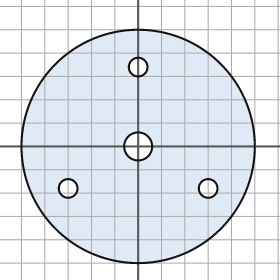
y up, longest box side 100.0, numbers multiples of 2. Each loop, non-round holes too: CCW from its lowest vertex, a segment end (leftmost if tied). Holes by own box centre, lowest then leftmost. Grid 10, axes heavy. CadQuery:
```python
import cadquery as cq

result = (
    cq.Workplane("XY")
    .moveTo(0.0, 0.0)
    .circle(50.0)
    .moveTo(-30.0, -18.0)
    .circle(4.0)
    .moveTo(30.0, -18.0)
    .circle(4.0)
    .moveTo(0.0, 0.0)
    .circle(6.0)
    .moveTo(0.0, 34.0)
    .circle(4.0)
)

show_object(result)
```